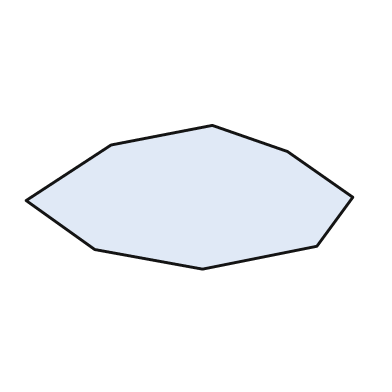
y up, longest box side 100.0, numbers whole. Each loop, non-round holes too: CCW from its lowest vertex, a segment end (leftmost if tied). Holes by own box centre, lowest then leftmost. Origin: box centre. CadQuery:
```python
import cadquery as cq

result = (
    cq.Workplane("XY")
    .moveTo(4.0, -22.0)
    .lineTo(39.0, -15.0)
    .lineTo(50.0, 0.0)
    .lineTo(30.0, 14.0)
    .lineTo(7.0, 22.0)
    .lineTo(-24.0, 16.0)
    .lineTo(-50.0, -1.0)
    .lineTo(-29.0, -16.0)
    .close()
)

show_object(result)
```